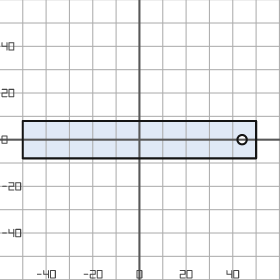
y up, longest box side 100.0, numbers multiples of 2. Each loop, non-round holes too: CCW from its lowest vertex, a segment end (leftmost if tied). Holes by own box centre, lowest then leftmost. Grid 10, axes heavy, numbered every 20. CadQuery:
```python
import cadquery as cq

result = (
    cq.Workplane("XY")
    .moveTo(-50.0, -8.0)
    .lineTo(50.0, -8.0)
    .lineTo(50.0, 8.0)
    .lineTo(-50.0, 8.0)
    .close()
    .moveTo(44.0, 0.0)
    .circle(2.0)
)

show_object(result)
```